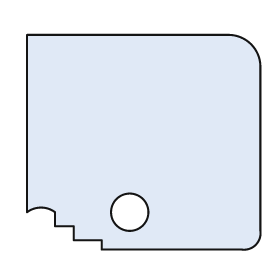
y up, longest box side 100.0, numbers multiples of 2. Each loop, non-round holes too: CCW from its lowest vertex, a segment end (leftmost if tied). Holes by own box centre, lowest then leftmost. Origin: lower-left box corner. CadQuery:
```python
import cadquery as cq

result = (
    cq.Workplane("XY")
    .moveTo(32.0, 0.0)
    .lineTo(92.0, 0.0)
    .threePointArc((98.0, 2.0), (100.0, 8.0))
    .lineTo(100.0, 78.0)
    .threePointArc((96.0, 88.0), (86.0, 92.0))
    .lineTo(0.0, 92.0)
    .lineTo(0.0, 16.0)
    .threePointArc((6.0, 18.0), (12.0, 16.0))
    .lineTo(12.0, 10.0)
    .lineTo(20.0, 10.0)
    .lineTo(20.0, 4.0)
    .lineTo(32.0, 4.0)
    .close()
    .moveTo(44.0, 16.0)
    .circle(8.0)
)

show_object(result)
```